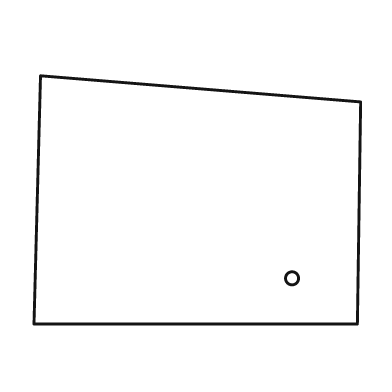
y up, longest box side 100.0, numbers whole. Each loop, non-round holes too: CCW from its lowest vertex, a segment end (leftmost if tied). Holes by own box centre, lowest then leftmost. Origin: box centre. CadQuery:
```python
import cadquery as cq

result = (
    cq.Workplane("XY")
    .moveTo(-50.0, -38.0)
    .lineTo(49.0, -38.0)
    .lineTo(50.0, 30.0)
    .lineTo(-48.0, 38.0)
    .close()
    .moveTo(29.0, -24.0)
    .circle(2.0)
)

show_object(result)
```